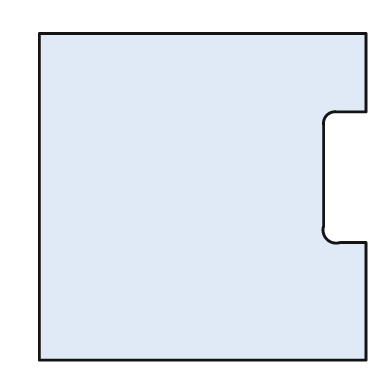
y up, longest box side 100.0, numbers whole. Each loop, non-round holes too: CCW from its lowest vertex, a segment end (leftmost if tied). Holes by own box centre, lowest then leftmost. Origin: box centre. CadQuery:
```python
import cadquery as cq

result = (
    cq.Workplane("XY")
    .moveTo(-50.0, -50.0)
    .lineTo(50.0, -50.0)
    .lineTo(50.0, -14.0)
    .lineTo(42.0, -14.0)
    .threePointArc((38.0, -13.0), (37.0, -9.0))
    .lineTo(37.0, 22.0)
    .threePointArc((38.0, 25.0), (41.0, 26.0))
    .lineTo(50.0, 26.0)
    .lineTo(50.0, 50.0)
    .lineTo(-50.0, 50.0)
    .close()
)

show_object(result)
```